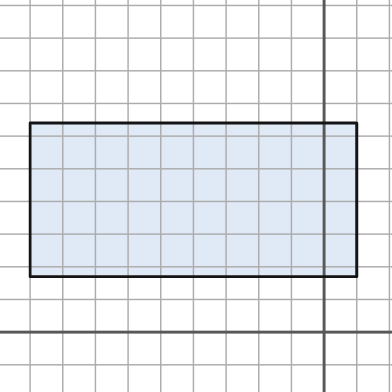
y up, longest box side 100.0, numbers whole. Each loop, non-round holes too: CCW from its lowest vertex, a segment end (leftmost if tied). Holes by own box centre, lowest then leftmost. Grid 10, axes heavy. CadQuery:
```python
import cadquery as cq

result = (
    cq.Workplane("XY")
    .moveTo(-90.0, 17.0)
    .lineTo(10.0, 17.0)
    .lineTo(10.0, 64.0)
    .lineTo(-90.0, 64.0)
    .close()
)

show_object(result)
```